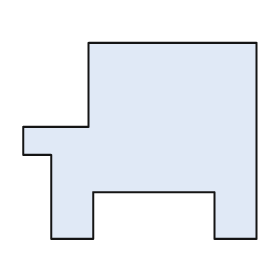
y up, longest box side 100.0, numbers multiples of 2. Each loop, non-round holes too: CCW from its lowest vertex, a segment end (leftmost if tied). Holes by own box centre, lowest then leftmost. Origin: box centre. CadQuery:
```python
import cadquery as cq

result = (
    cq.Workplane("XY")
    .moveTo(-38.0, -42.0)
    .lineTo(-20.0, -42.0)
    .lineTo(-20.0, -22.0)
    .lineTo(32.0, -22.0)
    .lineTo(32.0, -42.0)
    .lineTo(50.0, -42.0)
    .lineTo(50.0, 42.0)
    .lineTo(-22.0, 42.0)
    .lineTo(-22.0, 6.0)
    .lineTo(-50.0, 6.0)
    .lineTo(-50.0, -6.0)
    .lineTo(-38.0, -6.0)
    .close()
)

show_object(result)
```